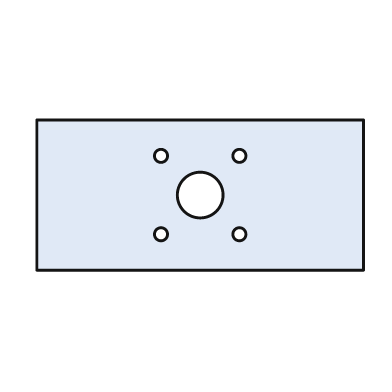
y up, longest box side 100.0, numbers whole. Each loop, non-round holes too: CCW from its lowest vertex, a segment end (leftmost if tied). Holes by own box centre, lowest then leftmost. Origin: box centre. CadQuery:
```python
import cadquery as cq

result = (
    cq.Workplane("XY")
    .moveTo(-50.0, -23.0)
    .lineTo(50.0, -23.0)
    .lineTo(50.0, 23.0)
    .lineTo(-50.0, 23.0)
    .close()
    .moveTo(-12.0, -12.0)
    .circle(2.0)
    .moveTo(12.0, -12.0)
    .circle(2.0)
    .moveTo(0.0, 0.0)
    .circle(7.0)
    .moveTo(-12.0, 12.0)
    .circle(2.0)
    .moveTo(12.0, 12.0)
    .circle(2.0)
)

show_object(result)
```